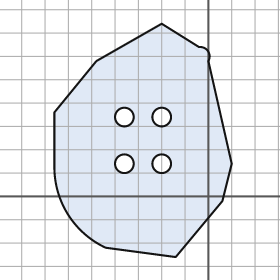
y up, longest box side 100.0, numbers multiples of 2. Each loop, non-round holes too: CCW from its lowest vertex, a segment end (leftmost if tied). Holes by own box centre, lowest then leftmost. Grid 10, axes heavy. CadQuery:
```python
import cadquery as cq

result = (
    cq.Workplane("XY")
    .moveTo(-14.0, -26.0)
    .lineTo(6.0, -2.0)
    .lineTo(10.0, 14.0)
    .lineTo(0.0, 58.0)
    .threePointArc((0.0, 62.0), (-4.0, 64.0))
    .lineTo(-20.0, 74.0)
    .lineTo(-48.0, 58.0)
    .lineTo(-66.0, 36.0)
    .lineTo(-66.0, 12.0)
    .threePointArc((-60.0, -8.0), (-44.0, -22.0))
    .close()
    .moveTo(-36.0, 14.0)
    .circle(4.0)
    .moveTo(-20.0, 14.0)
    .circle(4.0)
    .moveTo(-36.0, 34.0)
    .circle(4.0)
    .moveTo(-20.0, 34.0)
    .circle(4.0)
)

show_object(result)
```